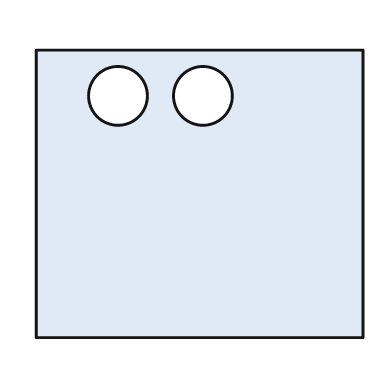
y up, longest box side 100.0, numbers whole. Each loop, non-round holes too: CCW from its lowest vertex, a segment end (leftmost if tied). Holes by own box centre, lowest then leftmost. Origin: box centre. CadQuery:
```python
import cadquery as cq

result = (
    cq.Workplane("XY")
    .moveTo(-50.0, -44.0)
    .lineTo(50.0, -44.0)
    .lineTo(50.0, 44.0)
    .lineTo(-50.0, 44.0)
    .close()
    .moveTo(-25.0, 30.0)
    .circle(9.0)
    .moveTo(1.0, 30.0)
    .circle(9.0)
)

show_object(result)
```